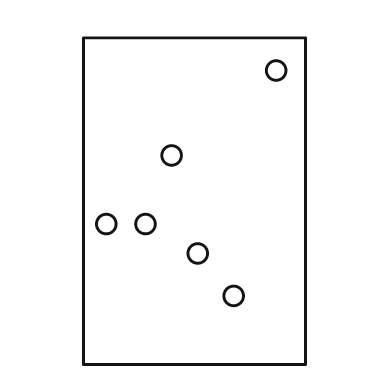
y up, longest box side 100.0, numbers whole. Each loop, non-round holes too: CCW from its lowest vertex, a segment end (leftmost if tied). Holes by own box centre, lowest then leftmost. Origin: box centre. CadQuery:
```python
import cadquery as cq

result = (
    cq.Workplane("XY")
    .moveTo(-34.0, -50.0)
    .lineTo(34.0, -50.0)
    .lineTo(34.0, 50.0)
    .lineTo(-34.0, 50.0)
    .close()
    .moveTo(12.0, -29.0)
    .circle(3.0)
    .moveTo(1.0, -16.0)
    .circle(3.0)
    .moveTo(-27.0, -7.0)
    .circle(3.0)
    .moveTo(-15.0, -7.0)
    .circle(3.0)
    .moveTo(-7.0, 14.0)
    .circle(3.0)
    .moveTo(25.0, 40.0)
    .circle(3.0)
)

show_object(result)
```